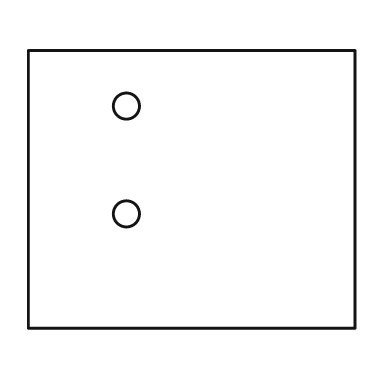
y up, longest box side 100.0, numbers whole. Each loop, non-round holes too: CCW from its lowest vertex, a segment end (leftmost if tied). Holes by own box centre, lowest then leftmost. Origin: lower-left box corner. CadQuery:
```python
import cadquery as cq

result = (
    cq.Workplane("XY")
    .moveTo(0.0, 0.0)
    .lineTo(100.0, 0.0)
    .lineTo(100.0, 85.0)
    .lineTo(0.0, 85.0)
    .close()
    .moveTo(30.0, 35.0)
    .circle(4.0)
    .moveTo(30.0, 68.0)
    .circle(4.0)
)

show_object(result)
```